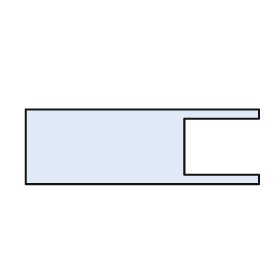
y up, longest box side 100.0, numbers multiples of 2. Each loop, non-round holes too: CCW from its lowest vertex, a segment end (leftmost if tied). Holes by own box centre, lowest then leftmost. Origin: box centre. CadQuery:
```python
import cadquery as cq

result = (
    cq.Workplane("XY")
    .moveTo(-50.0, -16.0)
    .lineTo(50.0, -16.0)
    .lineTo(50.0, -12.0)
    .lineTo(18.0, -12.0)
    .lineTo(18.0, 12.0)
    .lineTo(50.0, 12.0)
    .lineTo(50.0, 16.0)
    .lineTo(-50.0, 16.0)
    .close()
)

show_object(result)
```